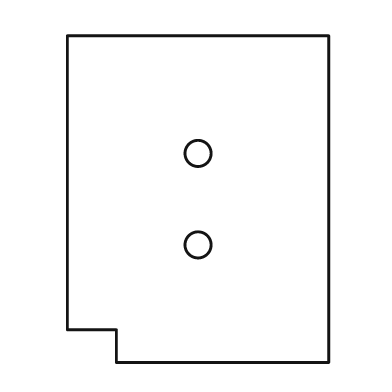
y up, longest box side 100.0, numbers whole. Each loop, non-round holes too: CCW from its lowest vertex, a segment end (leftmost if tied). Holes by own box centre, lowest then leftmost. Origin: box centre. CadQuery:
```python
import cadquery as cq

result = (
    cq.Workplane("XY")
    .moveTo(-25.0, -50.0)
    .lineTo(40.0, -50.0)
    .lineTo(40.0, 50.0)
    .lineTo(-40.0, 50.0)
    .lineTo(-40.0, -40.0)
    .lineTo(-25.0, -40.0)
    .close()
    .moveTo(0.0, -14.0)
    .circle(4.0)
    .moveTo(0.0, 14.0)
    .circle(4.0)
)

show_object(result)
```